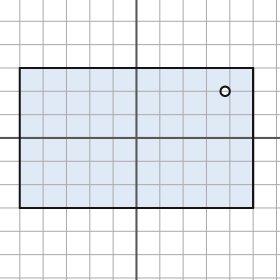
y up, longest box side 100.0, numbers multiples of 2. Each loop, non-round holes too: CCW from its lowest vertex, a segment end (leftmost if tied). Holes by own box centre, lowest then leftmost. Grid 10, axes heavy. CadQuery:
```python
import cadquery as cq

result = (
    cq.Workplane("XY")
    .moveTo(-50.0, -30.0)
    .lineTo(50.0, -30.0)
    .lineTo(50.0, 30.0)
    .lineTo(-50.0, 30.0)
    .close()
    .moveTo(38.0, 20.0)
    .circle(2.0)
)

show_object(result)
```